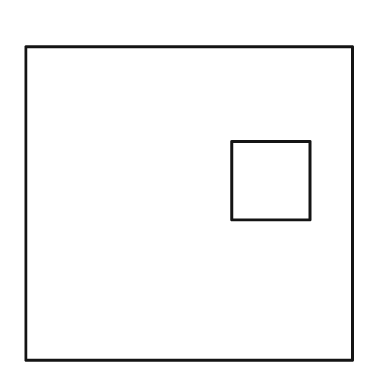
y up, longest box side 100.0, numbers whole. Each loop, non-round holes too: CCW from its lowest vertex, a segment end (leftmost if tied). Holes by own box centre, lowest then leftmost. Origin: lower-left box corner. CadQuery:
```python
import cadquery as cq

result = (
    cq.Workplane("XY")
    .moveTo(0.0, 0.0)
    .lineTo(100.0, 0.0)
    .lineTo(100.0, 96.0)
    .lineTo(0.0, 96.0)
    .close()
    .moveTo(63.0, 43.0)
    .lineTo(87.0, 43.0)
    .lineTo(87.0, 67.0)
    .lineTo(63.0, 67.0)
    .close()
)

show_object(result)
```